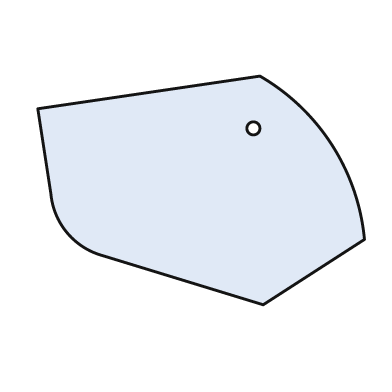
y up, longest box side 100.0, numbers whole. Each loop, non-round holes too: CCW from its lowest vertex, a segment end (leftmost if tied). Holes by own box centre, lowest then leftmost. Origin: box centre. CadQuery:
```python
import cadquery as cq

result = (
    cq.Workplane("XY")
    .moveTo(19.0, -35.0)
    .lineTo(50.0, -15.0)
    .threePointArc((40.0, 14.0), (18.0, 35.0))
    .lineTo(-50.0, 25.0)
    .lineTo(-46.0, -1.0)
    .threePointArc((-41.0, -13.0), (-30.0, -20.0))
    .close()
    .moveTo(16.0, 19.0)
    .circle(2.0)
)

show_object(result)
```